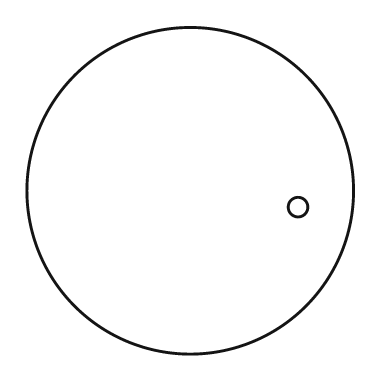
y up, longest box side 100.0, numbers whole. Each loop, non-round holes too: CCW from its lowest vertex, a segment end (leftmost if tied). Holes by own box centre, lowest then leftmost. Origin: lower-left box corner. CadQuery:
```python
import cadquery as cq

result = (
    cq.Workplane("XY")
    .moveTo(50.0, 50.0)
    .circle(50.0)
    .moveTo(83.0, 45.0)
    .circle(3.0)
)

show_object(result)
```